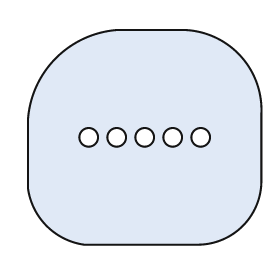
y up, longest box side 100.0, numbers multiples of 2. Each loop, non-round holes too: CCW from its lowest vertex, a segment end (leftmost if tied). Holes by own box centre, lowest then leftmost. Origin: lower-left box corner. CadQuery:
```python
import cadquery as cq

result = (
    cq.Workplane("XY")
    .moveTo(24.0, 0.0)
    .lineTo(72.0, 0.0)
    .threePointArc((92.0, 8.0), (100.0, 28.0))
    .lineTo(100.0, 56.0)
    .threePointArc((90.0, 82.0), (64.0, 92.0))
    .lineTo(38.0, 92.0)
    .threePointArc((12.0, 80.0), (0.0, 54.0))
    .lineTo(0.0, 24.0)
    .threePointArc((8.0, 8.0), (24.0, 0.0))
    .close()
    .moveTo(26.0, 46.0)
    .circle(4.0)
    .moveTo(38.0, 46.0)
    .circle(4.0)
    .moveTo(50.0, 46.0)
    .circle(4.0)
    .moveTo(62.0, 46.0)
    .circle(4.0)
    .moveTo(74.0, 46.0)
    .circle(4.0)
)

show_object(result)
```